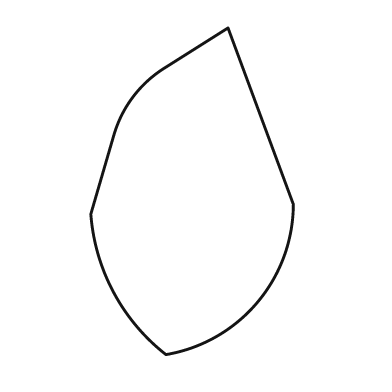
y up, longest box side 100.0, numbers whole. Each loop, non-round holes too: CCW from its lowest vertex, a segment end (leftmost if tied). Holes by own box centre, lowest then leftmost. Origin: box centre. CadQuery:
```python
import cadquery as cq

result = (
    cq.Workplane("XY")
    .moveTo(-8.0, -50.0)
    .threePointArc((20.0, -34.0), (31.0, -4.0))
    .lineTo(11.0, 50.0)
    .lineTo(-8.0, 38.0)
    .threePointArc((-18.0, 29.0), (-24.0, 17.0))
    .lineTo(-31.0, -7.0)
    .threePointArc((-24.0, -31.0), (-8.0, -50.0))
    .close()
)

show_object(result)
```